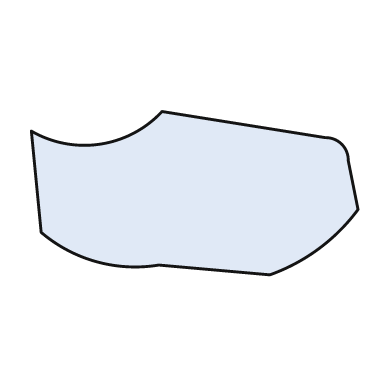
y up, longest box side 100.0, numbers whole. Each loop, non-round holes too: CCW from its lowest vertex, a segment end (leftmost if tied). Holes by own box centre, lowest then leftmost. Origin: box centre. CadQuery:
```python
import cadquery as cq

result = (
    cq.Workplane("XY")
    .moveTo(23.0, -25.0)
    .threePointArc((38.0, -17.0), (50.0, -5.0))
    .lineTo(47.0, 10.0)
    .threePointArc((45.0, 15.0), (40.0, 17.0))
    .lineTo(-10.0, 25.0)
    .threePointArc((-29.0, 15.0), (-50.0, 19.0))
    .lineTo(-47.0, -12.0)
    .threePointArc((-30.0, -21.0), (-11.0, -22.0))
    .close()
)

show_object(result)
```